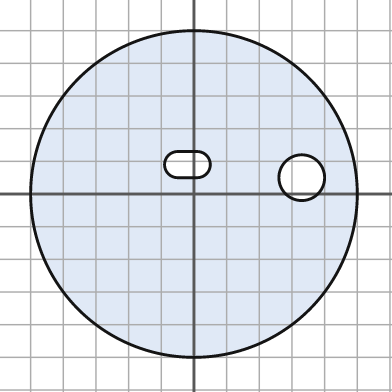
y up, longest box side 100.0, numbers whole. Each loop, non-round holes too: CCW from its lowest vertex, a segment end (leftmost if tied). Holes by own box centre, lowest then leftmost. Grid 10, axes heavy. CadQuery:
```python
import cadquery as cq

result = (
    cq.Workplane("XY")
    .moveTo(0.0, 0.0)
    .circle(50.0)
    .moveTo(33.0, 5.0)
    .circle(7.0)
    .moveTo(-5.0, 5.0)
    .lineTo(1.0, 5.0)
    .threePointArc((5.0, 9.0), (1.0, 13.0))
    .lineTo(-5.0, 13.0)
    .threePointArc((-9.0, 9.0), (-5.0, 5.0))
    .close()
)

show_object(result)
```